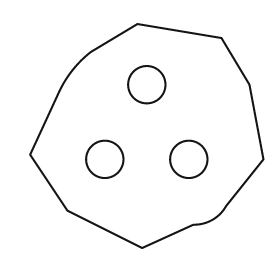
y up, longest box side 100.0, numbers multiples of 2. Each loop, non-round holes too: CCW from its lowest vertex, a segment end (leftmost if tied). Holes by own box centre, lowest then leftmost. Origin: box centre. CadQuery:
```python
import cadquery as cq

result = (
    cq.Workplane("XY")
    .moveTo(-2.0, -48.0)
    .lineTo(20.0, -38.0)
    .threePointArc((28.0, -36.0), (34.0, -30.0))
    .lineTo(50.0, -10.0)
    .lineTo(44.0, 22.0)
    .lineTo(32.0, 42.0)
    .lineTo(-4.0, 48.0)
    .lineTo(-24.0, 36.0)
    .threePointArc((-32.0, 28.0), (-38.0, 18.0))
    .lineTo(-50.0, -8.0)
    .lineTo(-34.0, -32.0)
    .close()
    .moveTo(-18.0, -10.0)
    .circle(8.0)
    .moveTo(18.0, -10.0)
    .circle(8.0)
    .moveTo(0.0, 22.0)
    .circle(8.0)
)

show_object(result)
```